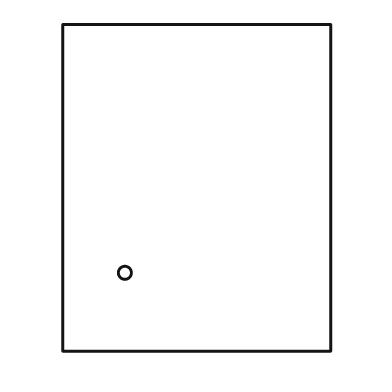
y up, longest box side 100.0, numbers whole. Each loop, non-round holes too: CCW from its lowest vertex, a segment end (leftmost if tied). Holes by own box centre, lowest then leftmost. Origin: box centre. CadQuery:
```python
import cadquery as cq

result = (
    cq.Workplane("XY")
    .moveTo(-41.0, -50.0)
    .lineTo(41.0, -50.0)
    .lineTo(41.0, 50.0)
    .lineTo(-41.0, 50.0)
    .close()
    .moveTo(-22.0, -26.0)
    .circle(2.0)
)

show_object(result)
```